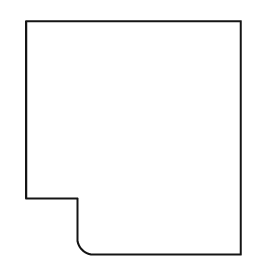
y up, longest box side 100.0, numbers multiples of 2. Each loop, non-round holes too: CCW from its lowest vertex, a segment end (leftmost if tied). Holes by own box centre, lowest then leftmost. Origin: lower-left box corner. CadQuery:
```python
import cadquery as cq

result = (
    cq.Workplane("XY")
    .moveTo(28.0, 0.0)
    .lineTo(92.0, 0.0)
    .lineTo(92.0, 100.0)
    .lineTo(0.0, 100.0)
    .lineTo(0.0, 24.0)
    .lineTo(22.0, 24.0)
    .lineTo(22.0, 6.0)
    .threePointArc((24.0, 2.0), (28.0, 0.0))
    .close()
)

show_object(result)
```